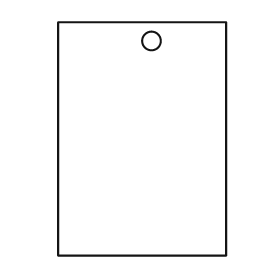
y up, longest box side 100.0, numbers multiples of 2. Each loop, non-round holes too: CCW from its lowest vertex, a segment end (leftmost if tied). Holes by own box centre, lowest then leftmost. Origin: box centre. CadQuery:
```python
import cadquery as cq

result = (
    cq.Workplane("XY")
    .moveTo(-36.0, -50.0)
    .lineTo(36.0, -50.0)
    .lineTo(36.0, 50.0)
    .lineTo(-36.0, 50.0)
    .close()
    .moveTo(4.0, 42.0)
    .circle(4.0)
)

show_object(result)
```